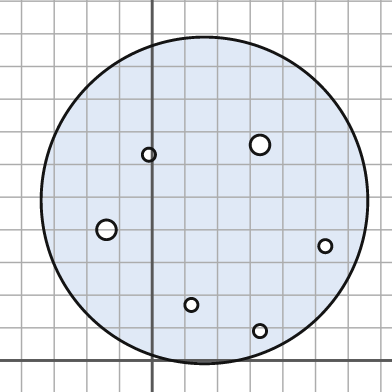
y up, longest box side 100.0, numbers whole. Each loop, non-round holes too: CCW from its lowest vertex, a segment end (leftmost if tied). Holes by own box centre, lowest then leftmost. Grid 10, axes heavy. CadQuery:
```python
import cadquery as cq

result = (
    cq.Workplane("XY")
    .moveTo(16.0, 49.0)
    .circle(50.0)
    .moveTo(33.0, 9.0)
    .circle(2.0)
    .moveTo(12.0, 17.0)
    .circle(2.0)
    .moveTo(53.0, 35.0)
    .circle(2.0)
    .moveTo(-14.0, 40.0)
    .circle(3.0)
    .moveTo(-1.0, 63.0)
    .circle(2.0)
    .moveTo(33.0, 66.0)
    .circle(3.0)
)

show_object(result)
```